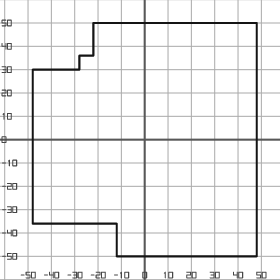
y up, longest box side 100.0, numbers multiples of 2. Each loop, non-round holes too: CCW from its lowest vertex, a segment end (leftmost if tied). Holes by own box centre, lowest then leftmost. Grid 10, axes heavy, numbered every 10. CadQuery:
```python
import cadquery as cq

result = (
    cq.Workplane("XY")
    .moveTo(-12.0, -50.0)
    .lineTo(48.0, -50.0)
    .lineTo(48.0, 50.0)
    .lineTo(-22.0, 50.0)
    .lineTo(-22.0, 36.0)
    .lineTo(-28.0, 36.0)
    .lineTo(-28.0, 30.0)
    .lineTo(-48.0, 30.0)
    .lineTo(-48.0, -36.0)
    .lineTo(-12.0, -36.0)
    .close()
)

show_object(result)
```